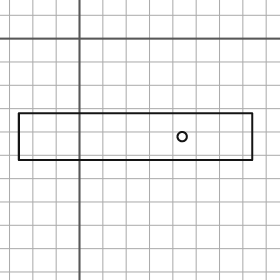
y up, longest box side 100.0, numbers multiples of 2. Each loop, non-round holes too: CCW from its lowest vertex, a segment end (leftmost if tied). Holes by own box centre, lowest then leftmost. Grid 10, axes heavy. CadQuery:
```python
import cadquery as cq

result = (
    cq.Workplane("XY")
    .moveTo(-26.0, -52.0)
    .lineTo(74.0, -52.0)
    .lineTo(74.0, -32.0)
    .lineTo(-26.0, -32.0)
    .close()
    .moveTo(44.0, -42.0)
    .circle(2.0)
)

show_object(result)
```